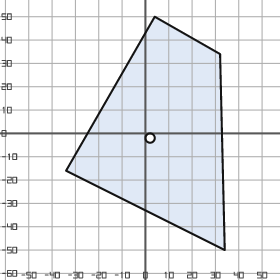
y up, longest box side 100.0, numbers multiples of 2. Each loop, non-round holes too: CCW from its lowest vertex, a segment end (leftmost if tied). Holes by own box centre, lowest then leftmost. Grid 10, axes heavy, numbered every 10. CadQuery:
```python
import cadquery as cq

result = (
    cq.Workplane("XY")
    .moveTo(34.0, -50.0)
    .lineTo(32.0, 34.0)
    .lineTo(4.0, 50.0)
    .lineTo(-34.0, -16.0)
    .close()
    .moveTo(2.0, -2.0)
    .circle(2.0)
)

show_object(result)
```